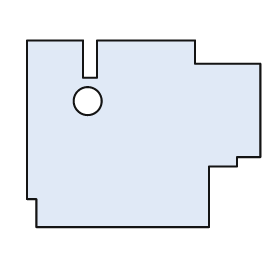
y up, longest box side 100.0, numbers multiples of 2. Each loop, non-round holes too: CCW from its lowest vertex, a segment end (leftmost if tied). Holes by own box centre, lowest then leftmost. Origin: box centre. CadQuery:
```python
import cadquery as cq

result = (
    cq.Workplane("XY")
    .moveTo(-46.0, -40.0)
    .lineTo(28.0, -40.0)
    .lineTo(28.0, -14.0)
    .lineTo(40.0, -14.0)
    .lineTo(40.0, -10.0)
    .lineTo(50.0, -10.0)
    .lineTo(50.0, 30.0)
    .lineTo(22.0, 30.0)
    .lineTo(22.0, 40.0)
    .lineTo(-20.0, 40.0)
    .lineTo(-20.0, 24.0)
    .lineTo(-26.0, 24.0)
    .lineTo(-26.0, 40.0)
    .lineTo(-50.0, 40.0)
    .lineTo(-50.0, -28.0)
    .lineTo(-46.0, -28.0)
    .close()
    .moveTo(-24.0, 14.0)
    .circle(6.0)
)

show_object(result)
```